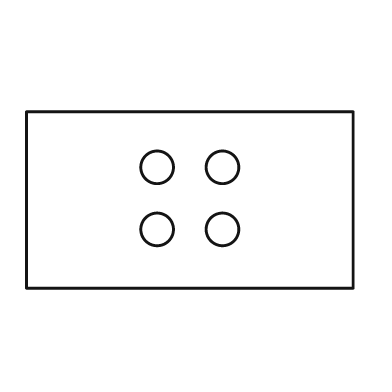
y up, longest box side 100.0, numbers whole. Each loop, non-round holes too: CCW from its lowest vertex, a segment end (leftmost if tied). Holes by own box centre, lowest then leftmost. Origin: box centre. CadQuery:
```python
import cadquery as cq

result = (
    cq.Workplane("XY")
    .moveTo(-50.0, -27.0)
    .lineTo(50.0, -27.0)
    .lineTo(50.0, 27.0)
    .lineTo(-50.0, 27.0)
    .close()
    .moveTo(-10.0, -9.0)
    .circle(5.0)
    .moveTo(10.0, -9.0)
    .circle(5.0)
    .moveTo(-10.0, 10.0)
    .circle(5.0)
    .moveTo(10.0, 10.0)
    .circle(5.0)
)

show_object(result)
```